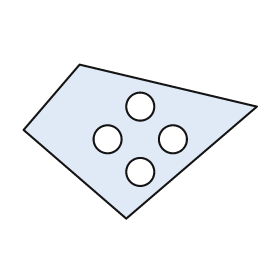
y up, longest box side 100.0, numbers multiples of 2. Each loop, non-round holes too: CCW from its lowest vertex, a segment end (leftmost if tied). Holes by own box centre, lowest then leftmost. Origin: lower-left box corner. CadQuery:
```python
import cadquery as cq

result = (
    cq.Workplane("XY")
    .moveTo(44.0, 0.0)
    .lineTo(100.0, 48.0)
    .lineTo(24.0, 66.0)
    .lineTo(0.0, 38.0)
    .close()
    .moveTo(50.0, 20.0)
    .circle(6.0)
    .moveTo(36.0, 34.0)
    .circle(6.0)
    .moveTo(64.0, 34.0)
    .circle(6.0)
    .moveTo(50.0, 48.0)
    .circle(6.0)
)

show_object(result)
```